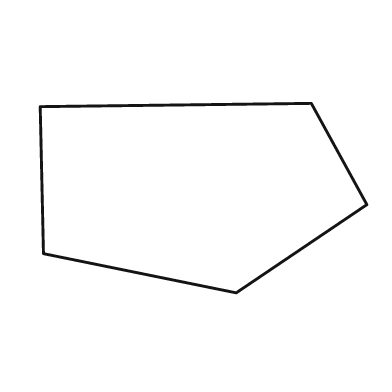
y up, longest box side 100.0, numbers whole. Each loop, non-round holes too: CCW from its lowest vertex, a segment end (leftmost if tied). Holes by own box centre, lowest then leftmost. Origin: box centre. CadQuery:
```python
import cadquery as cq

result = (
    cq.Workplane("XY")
    .moveTo(10.0, -29.0)
    .lineTo(50.0, -2.0)
    .lineTo(33.0, 29.0)
    .lineTo(-50.0, 28.0)
    .lineTo(-49.0, -17.0)
    .close()
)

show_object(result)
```